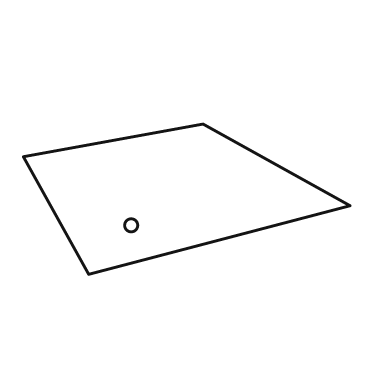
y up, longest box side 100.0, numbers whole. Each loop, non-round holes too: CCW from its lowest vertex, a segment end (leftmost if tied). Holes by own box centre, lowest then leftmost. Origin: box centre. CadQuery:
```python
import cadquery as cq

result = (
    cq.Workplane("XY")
    .moveTo(-30.0, -23.0)
    .lineTo(50.0, -2.0)
    .lineTo(5.0, 23.0)
    .lineTo(-50.0, 13.0)
    .close()
    .moveTo(-17.0, -8.0)
    .circle(2.0)
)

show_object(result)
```